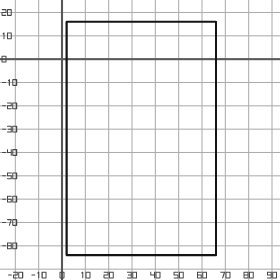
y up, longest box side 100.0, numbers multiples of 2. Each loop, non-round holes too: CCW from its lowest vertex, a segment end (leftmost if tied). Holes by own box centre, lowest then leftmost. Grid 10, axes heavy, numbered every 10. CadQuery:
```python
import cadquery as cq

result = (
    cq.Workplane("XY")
    .moveTo(2.0, -84.0)
    .lineTo(66.0, -84.0)
    .lineTo(66.0, 16.0)
    .lineTo(2.0, 16.0)
    .close()
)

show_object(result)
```